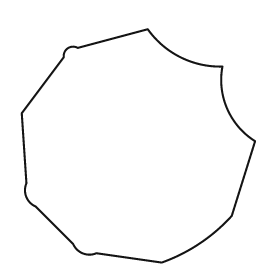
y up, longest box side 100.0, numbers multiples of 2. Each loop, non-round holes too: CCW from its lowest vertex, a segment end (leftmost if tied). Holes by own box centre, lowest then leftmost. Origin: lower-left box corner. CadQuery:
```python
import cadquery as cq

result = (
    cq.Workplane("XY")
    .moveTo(60.0, 0.0)
    .threePointArc((76.0, 8.0), (90.0, 20.0))
    .lineTo(100.0, 52.0)
    .threePointArc((88.0, 66.0), (86.0, 84.0))
    .threePointArc((68.0, 88.0), (54.0, 100.0))
    .lineTo(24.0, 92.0)
    .threePointArc((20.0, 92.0), (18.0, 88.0))
    .lineTo(0.0, 64.0)
    .lineTo(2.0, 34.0)
    .threePointArc((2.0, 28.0), (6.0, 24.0))
    .lineTo(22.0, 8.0)
    .threePointArc((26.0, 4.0), (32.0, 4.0))
    .close()
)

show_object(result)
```